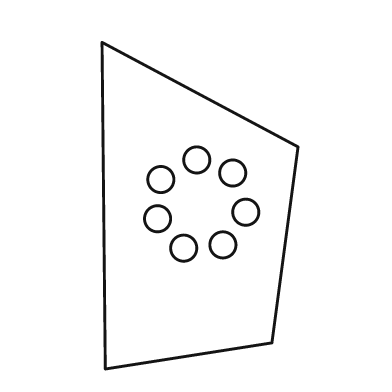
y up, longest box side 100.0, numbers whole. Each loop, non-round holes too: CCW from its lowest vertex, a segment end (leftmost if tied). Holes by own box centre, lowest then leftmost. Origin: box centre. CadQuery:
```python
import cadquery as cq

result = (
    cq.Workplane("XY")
    .moveTo(-29.0, -50.0)
    .lineTo(22.0, -42.0)
    .lineTo(30.0, 18.0)
    .lineTo(-30.0, 50.0)
    .close()
    .moveTo(-5.0, -13.0)
    .circle(4.0)
    .moveTo(7.0, -12.0)
    .circle(4.0)
    .moveTo(-13.0, -4.0)
    .circle(4.0)
    .moveTo(14.0, -2.0)
    .circle(4.0)
    .moveTo(-12.0, 8.0)
    .circle(4.0)
    .moveTo(10.0, 10.0)
    .circle(4.0)
    .moveTo(-1.0, 14.0)
    .circle(4.0)
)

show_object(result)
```